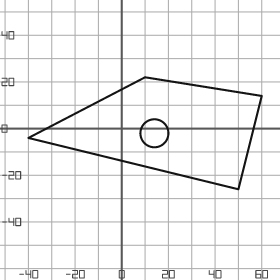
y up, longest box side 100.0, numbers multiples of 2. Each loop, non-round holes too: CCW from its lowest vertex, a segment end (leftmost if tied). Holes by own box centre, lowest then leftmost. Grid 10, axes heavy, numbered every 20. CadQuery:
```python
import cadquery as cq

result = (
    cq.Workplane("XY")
    .moveTo(50.0, -26.0)
    .lineTo(60.0, 14.0)
    .lineTo(10.0, 22.0)
    .lineTo(-40.0, -4.0)
    .close()
    .moveTo(14.0, -2.0)
    .circle(6.0)
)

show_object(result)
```